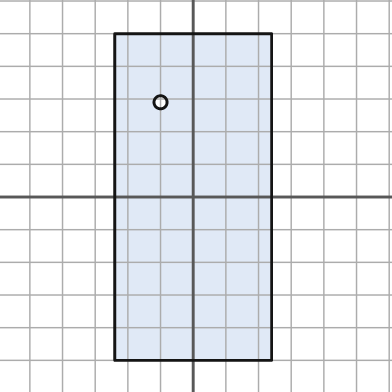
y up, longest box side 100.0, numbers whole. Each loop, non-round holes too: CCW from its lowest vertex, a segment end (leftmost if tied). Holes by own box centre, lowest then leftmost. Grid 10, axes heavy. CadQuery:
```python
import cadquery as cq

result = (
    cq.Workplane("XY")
    .moveTo(-24.0, -50.0)
    .lineTo(24.0, -50.0)
    .lineTo(24.0, 50.0)
    .lineTo(-24.0, 50.0)
    .close()
    .moveTo(-10.0, 29.0)
    .circle(2.0)
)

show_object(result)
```